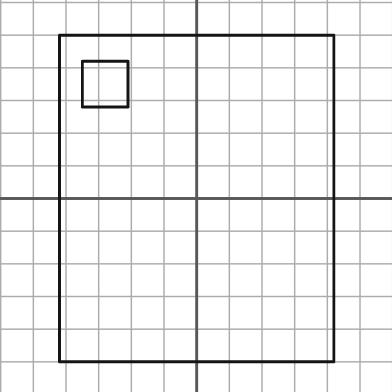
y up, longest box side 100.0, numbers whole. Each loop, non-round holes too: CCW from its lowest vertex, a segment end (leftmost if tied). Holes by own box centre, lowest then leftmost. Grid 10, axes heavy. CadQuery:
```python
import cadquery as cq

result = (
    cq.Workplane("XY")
    .moveTo(-42.0, -50.0)
    .lineTo(42.0, -50.0)
    .lineTo(42.0, 50.0)
    .lineTo(-42.0, 50.0)
    .close()
    .moveTo(-35.0, 28.0)
    .lineTo(-21.0, 28.0)
    .lineTo(-21.0, 42.0)
    .lineTo(-35.0, 42.0)
    .close()
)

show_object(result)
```